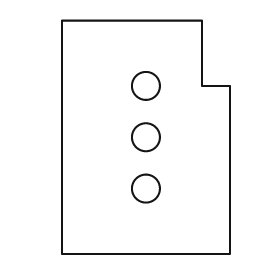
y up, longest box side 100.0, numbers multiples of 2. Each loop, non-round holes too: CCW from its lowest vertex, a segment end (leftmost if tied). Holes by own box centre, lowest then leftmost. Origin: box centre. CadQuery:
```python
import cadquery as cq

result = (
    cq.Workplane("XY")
    .moveTo(-36.0, -50.0)
    .lineTo(36.0, -50.0)
    .lineTo(36.0, 22.0)
    .lineTo(24.0, 22.0)
    .lineTo(24.0, 50.0)
    .lineTo(-36.0, 50.0)
    .close()
    .moveTo(0.0, -22.0)
    .circle(6.0)
    .moveTo(0.0, 0.0)
    .circle(6.0)
    .moveTo(0.0, 22.0)
    .circle(6.0)
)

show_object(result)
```